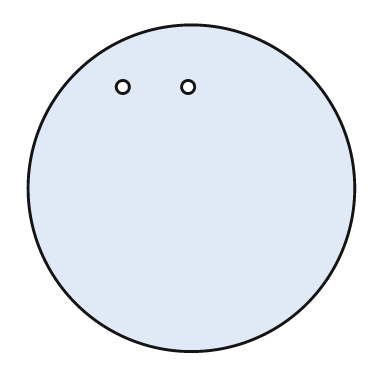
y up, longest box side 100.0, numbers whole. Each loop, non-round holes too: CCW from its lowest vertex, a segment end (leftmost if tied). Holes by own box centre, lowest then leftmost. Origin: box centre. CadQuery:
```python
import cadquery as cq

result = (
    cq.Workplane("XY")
    .moveTo(0.0, 0.0)
    .circle(50.0)
    .moveTo(-21.0, 31.0)
    .circle(2.0)
    .moveTo(-1.0, 31.0)
    .circle(2.0)
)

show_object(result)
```